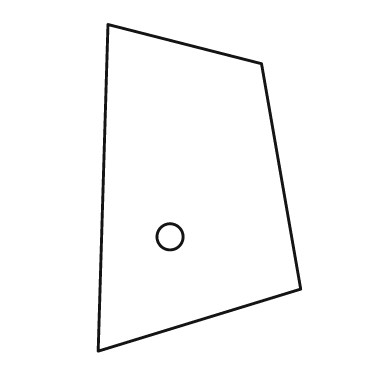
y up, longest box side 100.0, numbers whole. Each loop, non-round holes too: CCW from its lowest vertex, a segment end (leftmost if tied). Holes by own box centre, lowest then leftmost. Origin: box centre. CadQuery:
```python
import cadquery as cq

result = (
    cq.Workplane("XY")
    .moveTo(-31.0, -50.0)
    .lineTo(31.0, -31.0)
    .lineTo(19.0, 38.0)
    .lineTo(-28.0, 50.0)
    .close()
    .moveTo(-9.0, -15.0)
    .circle(4.0)
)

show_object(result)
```